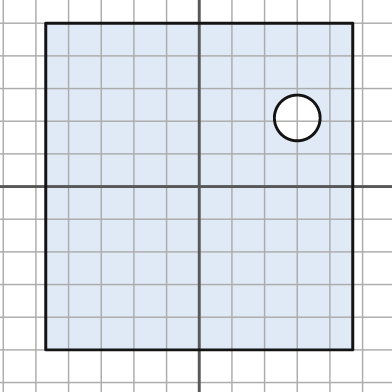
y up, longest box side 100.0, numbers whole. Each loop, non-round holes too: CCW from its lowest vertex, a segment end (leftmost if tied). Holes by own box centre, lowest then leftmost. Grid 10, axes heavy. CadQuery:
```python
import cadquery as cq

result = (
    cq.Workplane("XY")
    .moveTo(-47.0, -50.0)
    .lineTo(47.0, -50.0)
    .lineTo(47.0, 50.0)
    .lineTo(-47.0, 50.0)
    .close()
    .moveTo(30.0, 21.0)
    .circle(7.0)
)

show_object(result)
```